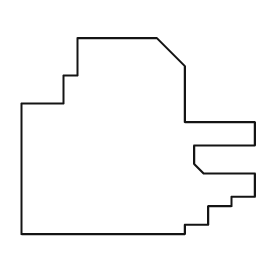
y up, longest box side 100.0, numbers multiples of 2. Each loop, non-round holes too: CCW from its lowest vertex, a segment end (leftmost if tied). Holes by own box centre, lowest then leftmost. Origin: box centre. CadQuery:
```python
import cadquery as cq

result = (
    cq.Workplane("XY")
    .moveTo(-50.0, -42.0)
    .lineTo(20.0, -42.0)
    .lineTo(20.0, -38.0)
    .lineTo(30.0, -38.0)
    .lineTo(30.0, -30.0)
    .lineTo(40.0, -30.0)
    .lineTo(40.0, -26.0)
    .lineTo(50.0, -26.0)
    .lineTo(50.0, -16.0)
    .lineTo(28.0, -16.0)
    .lineTo(24.0, -12.0)
    .lineTo(24.0, -4.0)
    .lineTo(50.0, -4.0)
    .lineTo(50.0, 6.0)
    .lineTo(20.0, 6.0)
    .lineTo(20.0, 30.0)
    .lineTo(8.0, 42.0)
    .lineTo(-26.0, 42.0)
    .lineTo(-26.0, 26.0)
    .lineTo(-32.0, 26.0)
    .lineTo(-32.0, 14.0)
    .lineTo(-50.0, 14.0)
    .close()
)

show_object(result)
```